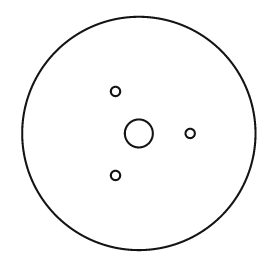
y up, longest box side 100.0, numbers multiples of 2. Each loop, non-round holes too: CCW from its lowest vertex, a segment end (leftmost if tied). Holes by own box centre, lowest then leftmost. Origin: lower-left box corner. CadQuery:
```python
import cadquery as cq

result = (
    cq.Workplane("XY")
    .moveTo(50.0, 50.0)
    .circle(50.0)
    .moveTo(40.0, 32.0)
    .circle(2.0)
    .moveTo(50.0, 50.0)
    .circle(6.0)
    .moveTo(72.0, 50.0)
    .circle(2.0)
    .moveTo(40.0, 68.0)
    .circle(2.0)
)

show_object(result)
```